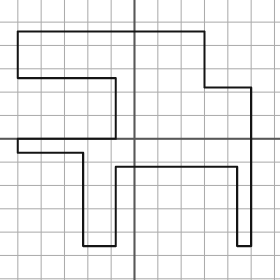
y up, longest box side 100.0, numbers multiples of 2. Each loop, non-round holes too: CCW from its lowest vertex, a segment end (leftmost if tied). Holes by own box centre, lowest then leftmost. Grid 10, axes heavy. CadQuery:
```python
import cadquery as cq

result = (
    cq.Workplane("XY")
    .moveTo(-22.0, -46.0)
    .lineTo(-8.0, -46.0)
    .lineTo(-8.0, -12.0)
    .lineTo(44.0, -12.0)
    .lineTo(44.0, -46.0)
    .lineTo(50.0, -46.0)
    .lineTo(50.0, 22.0)
    .lineTo(30.0, 22.0)
    .lineTo(30.0, 46.0)
    .lineTo(-50.0, 46.0)
    .lineTo(-50.0, 26.0)
    .lineTo(-8.0, 26.0)
    .lineTo(-8.0, 0.0)
    .lineTo(-50.0, 0.0)
    .lineTo(-50.0, -6.0)
    .lineTo(-22.0, -6.0)
    .close()
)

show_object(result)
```